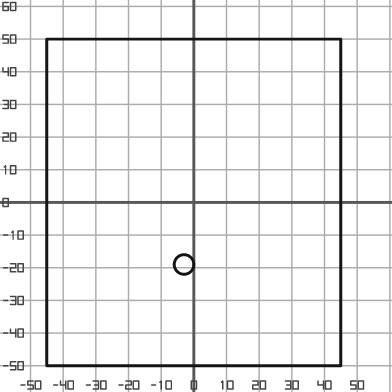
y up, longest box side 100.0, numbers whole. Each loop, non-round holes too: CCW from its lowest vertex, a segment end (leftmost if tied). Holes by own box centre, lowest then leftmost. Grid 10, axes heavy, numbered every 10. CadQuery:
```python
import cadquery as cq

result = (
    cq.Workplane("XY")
    .moveTo(-45.0, -50.0)
    .lineTo(45.0, -50.0)
    .lineTo(45.0, 50.0)
    .lineTo(-45.0, 50.0)
    .close()
    .moveTo(-3.0, -19.0)
    .circle(3.0)
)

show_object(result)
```